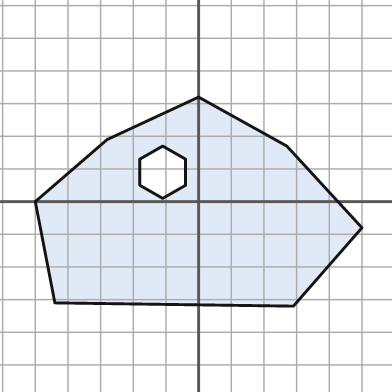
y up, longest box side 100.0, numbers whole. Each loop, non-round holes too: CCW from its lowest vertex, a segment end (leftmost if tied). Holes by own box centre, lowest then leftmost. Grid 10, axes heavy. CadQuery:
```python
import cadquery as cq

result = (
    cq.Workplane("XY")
    .moveTo(29.0, -32.0)
    .lineTo(50.0, -8.0)
    .lineTo(27.0, 17.0)
    .lineTo(0.0, 32.0)
    .lineTo(-28.0, 19.0)
    .lineTo(-50.0, 0.0)
    .lineTo(-44.0, -31.0)
    .close()
    .moveTo(-11.0, 1.0)
    .lineTo(-4.0, 5.0)
    .lineTo(-4.0, 13.0)
    .lineTo(-11.0, 17.0)
    .lineTo(-18.0, 13.0)
    .lineTo(-18.0, 5.0)
    .close()
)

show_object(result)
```